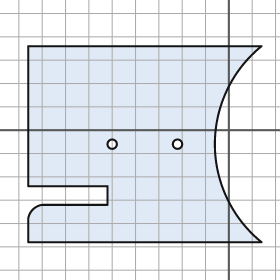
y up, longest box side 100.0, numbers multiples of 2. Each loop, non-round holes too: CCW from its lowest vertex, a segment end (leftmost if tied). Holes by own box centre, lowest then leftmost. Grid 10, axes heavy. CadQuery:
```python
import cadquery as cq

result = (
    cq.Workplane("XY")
    .moveTo(-86.0, -48.0)
    .lineTo(14.0, -48.0)
    .threePointArc((-6.0, -6.0), (14.0, 36.0))
    .lineTo(-86.0, 36.0)
    .lineTo(-86.0, -24.0)
    .lineTo(-52.0, -24.0)
    .lineTo(-52.0, -32.0)
    .lineTo(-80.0, -32.0)
    .threePointArc((-84.0, -34.0), (-86.0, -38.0))
    .close()
    .moveTo(-50.0, -6.0)
    .circle(2.0)
    .moveTo(-22.0, -6.0)
    .circle(2.0)
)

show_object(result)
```